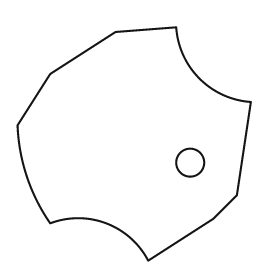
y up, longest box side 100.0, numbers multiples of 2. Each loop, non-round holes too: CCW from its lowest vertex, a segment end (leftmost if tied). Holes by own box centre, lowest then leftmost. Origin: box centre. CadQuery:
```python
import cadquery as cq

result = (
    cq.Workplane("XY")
    .moveTo(6.0, -50.0)
    .lineTo(34.0, -32.0)
    .lineTo(44.0, -22.0)
    .lineTo(50.0, 18.0)
    .threePointArc((28.0, 28.0), (18.0, 50.0))
    .lineTo(-8.0, 48.0)
    .lineTo(-36.0, 30.0)
    .lineTo(-50.0, 8.0)
    .threePointArc((-46.0, -14.0), (-36.0, -34.0))
    .threePointArc((-12.0, -34.0), (6.0, -50.0))
    .close()
    .moveTo(24.0, -8.0)
    .circle(6.0)
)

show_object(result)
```